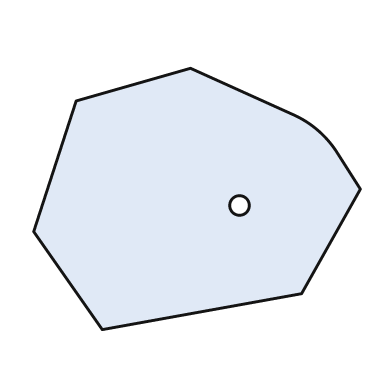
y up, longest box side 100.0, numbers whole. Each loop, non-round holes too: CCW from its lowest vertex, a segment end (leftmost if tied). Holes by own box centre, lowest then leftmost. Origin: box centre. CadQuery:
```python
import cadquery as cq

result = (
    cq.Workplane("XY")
    .moveTo(-29.0, -40.0)
    .lineTo(32.0, -29.0)
    .lineTo(50.0, 3.0)
    .lineTo(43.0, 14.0)
    .threePointArc((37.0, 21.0), (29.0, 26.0))
    .lineTo(-2.0, 40.0)
    .lineTo(-37.0, 30.0)
    .lineTo(-50.0, -10.0)
    .close()
    .moveTo(13.0, -2.0)
    .circle(3.0)
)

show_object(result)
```